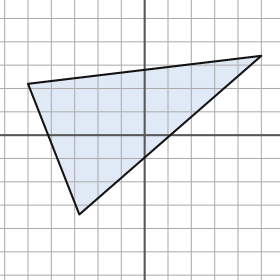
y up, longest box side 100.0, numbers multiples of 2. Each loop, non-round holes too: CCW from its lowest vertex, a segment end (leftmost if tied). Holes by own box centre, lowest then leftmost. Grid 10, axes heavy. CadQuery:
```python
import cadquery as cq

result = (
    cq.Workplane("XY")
    .moveTo(-28.0, -34.0)
    .lineTo(50.0, 34.0)
    .lineTo(-50.0, 22.0)
    .close()
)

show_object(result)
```